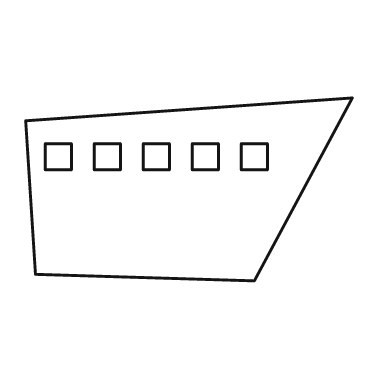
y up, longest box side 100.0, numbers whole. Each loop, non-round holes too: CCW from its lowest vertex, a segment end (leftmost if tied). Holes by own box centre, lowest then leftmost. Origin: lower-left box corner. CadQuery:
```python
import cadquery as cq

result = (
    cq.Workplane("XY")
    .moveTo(70.0, 0.0)
    .lineTo(100.0, 56.0)
    .lineTo(0.0, 49.0)
    .lineTo(3.0, 2.0)
    .close()
    .moveTo(6.0, 34.0)
    .lineTo(14.0, 34.0)
    .lineTo(14.0, 42.0)
    .lineTo(6.0, 42.0)
    .close()
    .moveTo(21.0, 34.0)
    .lineTo(29.0, 34.0)
    .lineTo(29.0, 42.0)
    .lineTo(21.0, 42.0)
    .close()
    .moveTo(36.0, 34.0)
    .lineTo(44.0, 34.0)
    .lineTo(44.0, 42.0)
    .lineTo(36.0, 42.0)
    .close()
    .moveTo(51.0, 34.0)
    .lineTo(59.0, 34.0)
    .lineTo(59.0, 42.0)
    .lineTo(51.0, 42.0)
    .close()
    .moveTo(66.0, 34.0)
    .lineTo(74.0, 34.0)
    .lineTo(74.0, 42.0)
    .lineTo(66.0, 42.0)
    .close()
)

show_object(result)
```